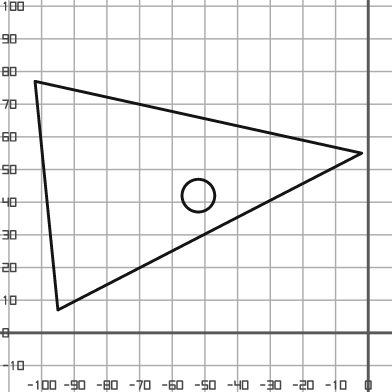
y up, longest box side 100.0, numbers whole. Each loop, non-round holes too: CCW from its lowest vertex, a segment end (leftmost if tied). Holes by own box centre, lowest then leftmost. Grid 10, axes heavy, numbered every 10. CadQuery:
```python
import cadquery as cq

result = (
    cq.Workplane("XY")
    .moveTo(-95.0, 7.0)
    .lineTo(-2.0, 55.0)
    .lineTo(-102.0, 77.0)
    .close()
    .moveTo(-52.0, 42.0)
    .circle(5.0)
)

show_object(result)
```